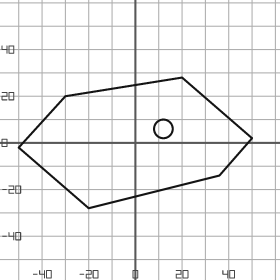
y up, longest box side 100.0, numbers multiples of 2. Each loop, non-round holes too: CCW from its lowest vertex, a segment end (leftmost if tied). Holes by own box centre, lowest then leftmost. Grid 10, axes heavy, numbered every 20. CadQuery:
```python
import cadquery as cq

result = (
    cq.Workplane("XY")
    .moveTo(-20.0, -28.0)
    .lineTo(36.0, -14.0)
    .lineTo(50.0, 2.0)
    .lineTo(20.0, 28.0)
    .lineTo(-30.0, 20.0)
    .lineTo(-50.0, -2.0)
    .close()
    .moveTo(12.0, 6.0)
    .circle(4.0)
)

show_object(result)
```